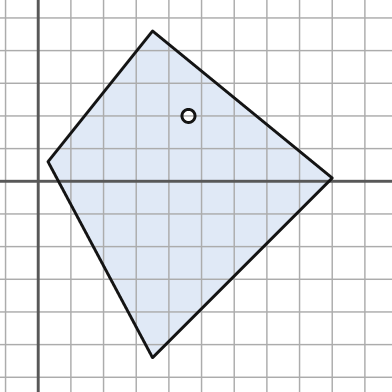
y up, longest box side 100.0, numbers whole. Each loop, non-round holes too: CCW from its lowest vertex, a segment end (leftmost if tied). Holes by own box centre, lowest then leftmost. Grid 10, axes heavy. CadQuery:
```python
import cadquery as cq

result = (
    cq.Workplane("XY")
    .moveTo(35.0, -54.0)
    .lineTo(90.0, 1.0)
    .lineTo(35.0, 46.0)
    .lineTo(3.0, 6.0)
    .close()
    .moveTo(46.0, 20.0)
    .circle(2.0)
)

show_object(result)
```